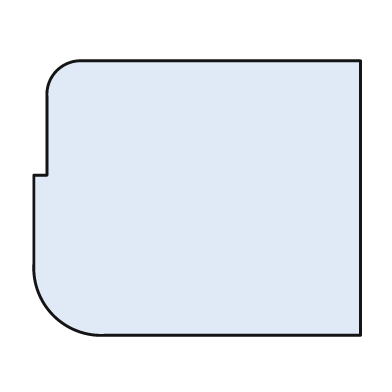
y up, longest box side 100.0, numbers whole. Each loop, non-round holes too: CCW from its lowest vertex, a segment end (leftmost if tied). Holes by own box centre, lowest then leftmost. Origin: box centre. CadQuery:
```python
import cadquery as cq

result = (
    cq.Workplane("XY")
    .moveTo(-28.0, -42.0)
    .lineTo(50.0, -42.0)
    .lineTo(50.0, 42.0)
    .lineTo(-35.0, 42.0)
    .threePointArc((-43.0, 39.0), (-46.0, 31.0))
    .lineTo(-46.0, 7.0)
    .lineTo(-50.0, 7.0)
    .lineTo(-50.0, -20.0)
    .threePointArc((-44.0, -36.0), (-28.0, -42.0))
    .close()
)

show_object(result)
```